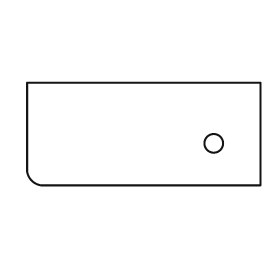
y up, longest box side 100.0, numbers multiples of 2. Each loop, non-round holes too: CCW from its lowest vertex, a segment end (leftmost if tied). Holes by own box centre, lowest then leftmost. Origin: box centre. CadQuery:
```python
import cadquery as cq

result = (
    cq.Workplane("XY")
    .moveTo(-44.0, -22.0)
    .lineTo(50.0, -22.0)
    .lineTo(50.0, 22.0)
    .lineTo(-50.0, 22.0)
    .lineTo(-50.0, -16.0)
    .threePointArc((-48.0, -20.0), (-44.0, -22.0))
    .close()
    .moveTo(30.0, -4.0)
    .circle(4.0)
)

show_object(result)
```